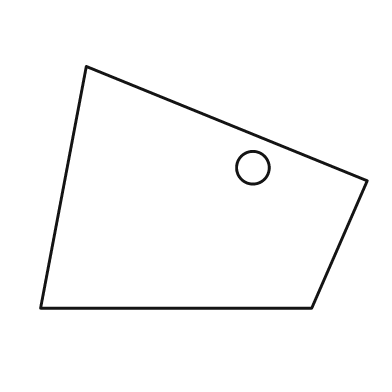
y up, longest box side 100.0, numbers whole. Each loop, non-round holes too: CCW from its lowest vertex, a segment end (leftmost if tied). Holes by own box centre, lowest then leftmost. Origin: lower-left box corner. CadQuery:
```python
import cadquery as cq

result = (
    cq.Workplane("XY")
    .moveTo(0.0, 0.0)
    .lineTo(83.0, 0.0)
    .lineTo(100.0, 39.0)
    .lineTo(14.0, 74.0)
    .close()
    .moveTo(65.0, 43.0)
    .circle(5.0)
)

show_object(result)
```